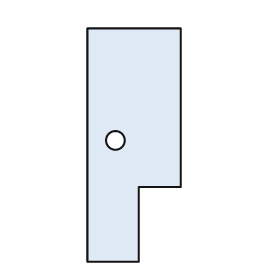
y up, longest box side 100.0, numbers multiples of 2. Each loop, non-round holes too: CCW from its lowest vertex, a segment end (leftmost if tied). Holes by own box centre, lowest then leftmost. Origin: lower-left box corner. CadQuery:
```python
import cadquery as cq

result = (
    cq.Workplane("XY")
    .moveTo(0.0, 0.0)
    .lineTo(22.0, 0.0)
    .lineTo(22.0, 32.0)
    .lineTo(40.0, 32.0)
    .lineTo(40.0, 100.0)
    .lineTo(0.0, 100.0)
    .close()
    .moveTo(12.0, 52.0)
    .circle(4.0)
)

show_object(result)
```